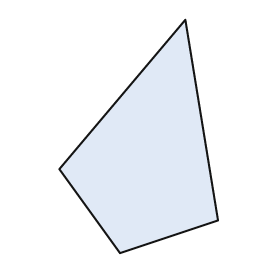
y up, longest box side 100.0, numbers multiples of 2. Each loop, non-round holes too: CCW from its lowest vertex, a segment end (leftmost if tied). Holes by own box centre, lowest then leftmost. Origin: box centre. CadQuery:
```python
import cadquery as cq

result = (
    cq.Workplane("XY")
    .moveTo(-8.0, -50.0)
    .lineTo(34.0, -36.0)
    .lineTo(20.0, 50.0)
    .lineTo(-34.0, -14.0)
    .close()
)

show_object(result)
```